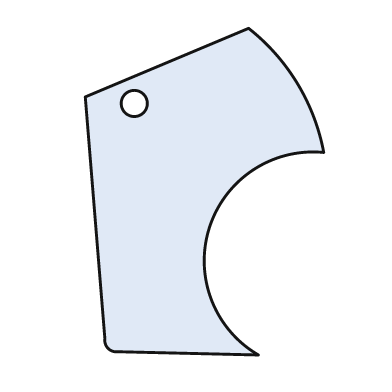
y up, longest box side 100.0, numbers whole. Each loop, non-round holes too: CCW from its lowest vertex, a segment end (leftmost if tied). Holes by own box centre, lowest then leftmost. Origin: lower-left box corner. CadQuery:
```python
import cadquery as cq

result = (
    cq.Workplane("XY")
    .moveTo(53.0, 0.0)
    .threePointArc((38.0, 39.0), (73.0, 62.0))
    .threePointArc((65.0, 83.0), (50.0, 100.0))
    .lineTo(0.0, 79.0)
    .lineTo(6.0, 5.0)
    .threePointArc((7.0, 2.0), (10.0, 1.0))
    .close()
    .moveTo(15.0, 77.0)
    .circle(4.0)
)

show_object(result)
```